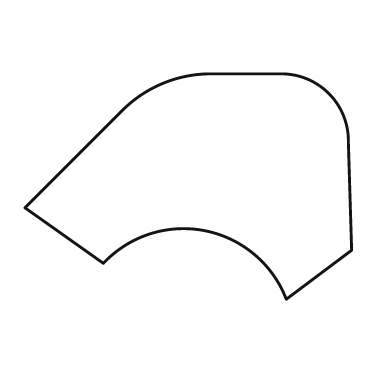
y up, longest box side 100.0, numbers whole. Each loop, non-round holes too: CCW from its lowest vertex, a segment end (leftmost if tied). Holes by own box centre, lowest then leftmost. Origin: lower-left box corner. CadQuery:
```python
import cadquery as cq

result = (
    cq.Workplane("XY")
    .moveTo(80.0, 0.0)
    .lineTo(100.0, 15.0)
    .lineTo(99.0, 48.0)
    .threePointArc((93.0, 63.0), (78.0, 69.0))
    .lineTo(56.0, 69.0)
    .threePointArc((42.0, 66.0), (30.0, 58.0))
    .lineTo(0.0, 28.0)
    .lineTo(24.0, 11.0)
    .threePointArc((55.0, 21.0), (80.0, 0.0))
    .close()
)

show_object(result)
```